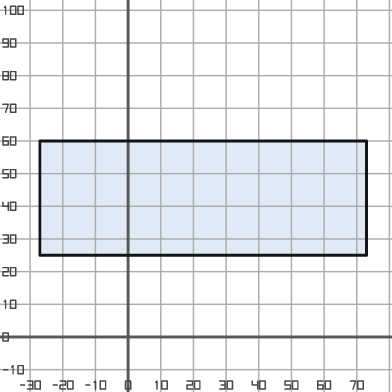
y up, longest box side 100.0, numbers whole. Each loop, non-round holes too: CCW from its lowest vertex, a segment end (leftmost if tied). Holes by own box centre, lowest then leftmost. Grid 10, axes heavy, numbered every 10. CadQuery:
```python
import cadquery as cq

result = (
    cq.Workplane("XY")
    .moveTo(-27.0, 25.0)
    .lineTo(73.0, 25.0)
    .lineTo(73.0, 60.0)
    .lineTo(-27.0, 60.0)
    .close()
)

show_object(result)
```